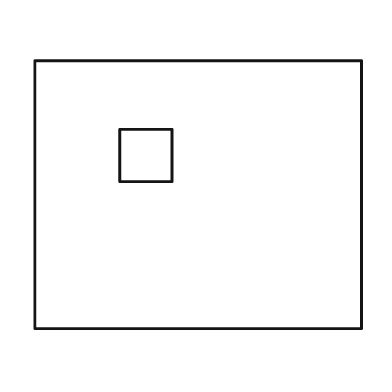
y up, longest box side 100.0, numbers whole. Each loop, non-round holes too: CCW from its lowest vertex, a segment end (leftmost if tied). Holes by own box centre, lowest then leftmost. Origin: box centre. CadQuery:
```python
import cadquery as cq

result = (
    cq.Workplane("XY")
    .moveTo(-50.0, -41.0)
    .lineTo(50.0, -41.0)
    .lineTo(50.0, 41.0)
    .lineTo(-50.0, 41.0)
    .close()
    .moveTo(-24.0, 4.0)
    .lineTo(-8.0, 4.0)
    .lineTo(-8.0, 20.0)
    .lineTo(-24.0, 20.0)
    .close()
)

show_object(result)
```